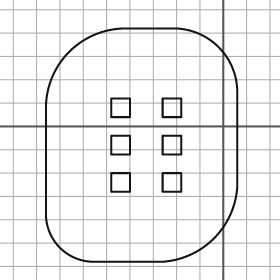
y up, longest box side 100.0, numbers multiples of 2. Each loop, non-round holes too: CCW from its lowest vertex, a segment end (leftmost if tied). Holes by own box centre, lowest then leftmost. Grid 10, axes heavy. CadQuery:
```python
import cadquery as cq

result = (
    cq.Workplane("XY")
    .moveTo(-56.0, -58.0)
    .lineTo(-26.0, -58.0)
    .threePointArc((-4.0, -48.0), (6.0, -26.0))
    .lineTo(6.0, 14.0)
    .threePointArc((-2.0, 34.0), (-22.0, 42.0))
    .lineTo(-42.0, 42.0)
    .threePointArc((-66.0, 32.0), (-76.0, 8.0))
    .lineTo(-76.0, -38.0)
    .threePointArc((-70.0, -52.0), (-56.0, -58.0))
    .close()
    .moveTo(-48.0, -28.0)
    .lineTo(-40.0, -28.0)
    .lineTo(-40.0, -20.0)
    .lineTo(-48.0, -20.0)
    .close()
    .moveTo(-26.0, -28.0)
    .lineTo(-18.0, -28.0)
    .lineTo(-18.0, -20.0)
    .lineTo(-26.0, -20.0)
    .close()
    .moveTo(-48.0, -12.0)
    .lineTo(-40.0, -12.0)
    .lineTo(-40.0, -4.0)
    .lineTo(-48.0, -4.0)
    .close()
    .moveTo(-26.0, -12.0)
    .lineTo(-18.0, -12.0)
    .lineTo(-18.0, -4.0)
    .lineTo(-26.0, -4.0)
    .close()
    .moveTo(-48.0, 4.0)
    .lineTo(-40.0, 4.0)
    .lineTo(-40.0, 12.0)
    .lineTo(-48.0, 12.0)
    .close()
    .moveTo(-26.0, 4.0)
    .lineTo(-18.0, 4.0)
    .lineTo(-18.0, 12.0)
    .lineTo(-26.0, 12.0)
    .close()
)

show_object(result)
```